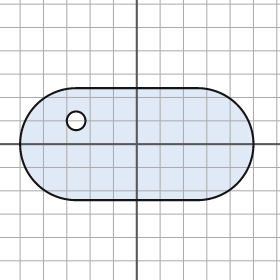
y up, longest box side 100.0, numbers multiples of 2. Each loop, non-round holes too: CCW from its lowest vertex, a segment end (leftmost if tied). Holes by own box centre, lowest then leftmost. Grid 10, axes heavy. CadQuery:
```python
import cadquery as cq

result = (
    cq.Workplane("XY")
    .moveTo(-26.0, -24.0)
    .lineTo(26.0, -24.0)
    .threePointArc((50.0, 0.0), (26.0, 24.0))
    .lineTo(-26.0, 24.0)
    .threePointArc((-50.0, 0.0), (-26.0, -24.0))
    .close()
    .moveTo(-26.0, 10.0)
    .circle(4.0)
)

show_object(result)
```